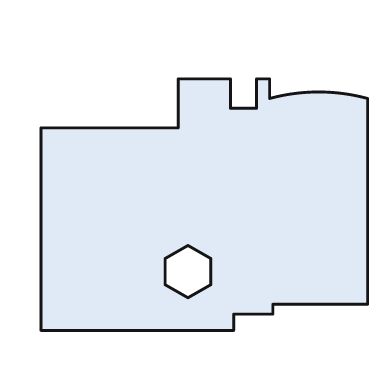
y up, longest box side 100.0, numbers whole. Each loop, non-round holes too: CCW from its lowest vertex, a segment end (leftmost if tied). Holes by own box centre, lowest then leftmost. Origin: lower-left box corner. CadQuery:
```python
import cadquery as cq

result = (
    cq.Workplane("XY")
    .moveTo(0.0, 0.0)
    .lineTo(59.0, 0.0)
    .lineTo(59.0, 5.0)
    .lineTo(71.0, 5.0)
    .lineTo(71.0, 8.0)
    .lineTo(100.0, 8.0)
    .lineTo(100.0, 71.0)
    .threePointArc((85.0, 73.0), (70.0, 71.0))
    .lineTo(70.0, 77.0)
    .lineTo(66.0, 77.0)
    .lineTo(66.0, 68.0)
    .lineTo(58.0, 68.0)
    .lineTo(58.0, 77.0)
    .lineTo(42.0, 77.0)
    .lineTo(42.0, 62.0)
    .lineTo(0.0, 62.0)
    .close()
    .moveTo(45.0, 10.0)
    .lineTo(52.0, 14.0)
    .lineTo(52.0, 22.0)
    .lineTo(45.0, 26.0)
    .lineTo(38.0, 22.0)
    .lineTo(38.0, 14.0)
    .close()
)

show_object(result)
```